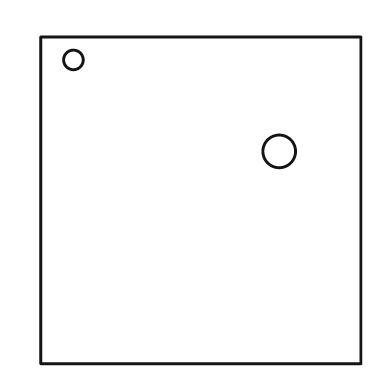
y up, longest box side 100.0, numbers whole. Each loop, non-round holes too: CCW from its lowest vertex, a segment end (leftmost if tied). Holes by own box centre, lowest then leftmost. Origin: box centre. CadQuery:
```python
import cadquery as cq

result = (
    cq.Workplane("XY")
    .moveTo(-49.0, -50.0)
    .lineTo(49.0, -50.0)
    .lineTo(49.0, 50.0)
    .lineTo(-49.0, 50.0)
    .close()
    .moveTo(24.0, 15.0)
    .circle(5.0)
    .moveTo(-39.0, 43.0)
    .circle(3.0)
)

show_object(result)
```